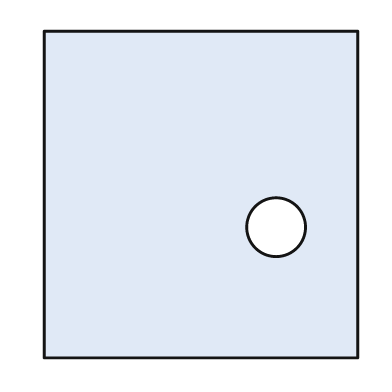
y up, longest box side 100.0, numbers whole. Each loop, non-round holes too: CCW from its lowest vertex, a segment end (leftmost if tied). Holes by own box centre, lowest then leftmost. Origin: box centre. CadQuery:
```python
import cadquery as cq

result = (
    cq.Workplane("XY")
    .moveTo(-48.0, -50.0)
    .lineTo(48.0, -50.0)
    .lineTo(48.0, 50.0)
    .lineTo(-48.0, 50.0)
    .close()
    .moveTo(23.0, -10.0)
    .circle(9.0)
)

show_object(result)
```